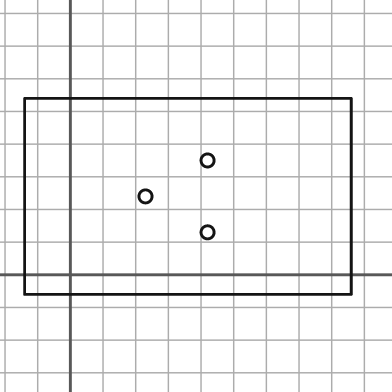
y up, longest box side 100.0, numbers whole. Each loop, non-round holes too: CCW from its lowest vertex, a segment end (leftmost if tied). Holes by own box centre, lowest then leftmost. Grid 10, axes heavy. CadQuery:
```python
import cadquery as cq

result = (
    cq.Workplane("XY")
    .moveTo(-14.0, -6.0)
    .lineTo(86.0, -6.0)
    .lineTo(86.0, 54.0)
    .lineTo(-14.0, 54.0)
    .close()
    .moveTo(42.0, 13.0)
    .circle(2.0)
    .moveTo(23.0, 24.0)
    .circle(2.0)
    .moveTo(42.0, 35.0)
    .circle(2.0)
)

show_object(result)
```